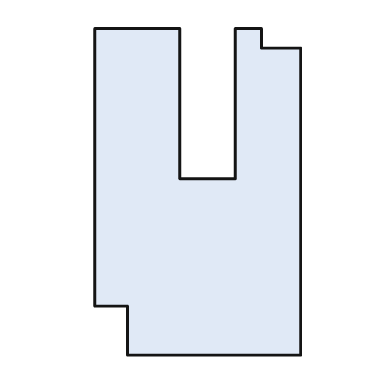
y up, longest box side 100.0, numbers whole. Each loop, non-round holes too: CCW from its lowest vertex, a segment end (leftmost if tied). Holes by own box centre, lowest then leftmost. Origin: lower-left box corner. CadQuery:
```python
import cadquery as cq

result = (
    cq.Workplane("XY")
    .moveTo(10.0, 0.0)
    .lineTo(63.0, 0.0)
    .lineTo(63.0, 94.0)
    .lineTo(51.0, 94.0)
    .lineTo(51.0, 100.0)
    .lineTo(43.0, 100.0)
    .lineTo(43.0, 54.0)
    .lineTo(26.0, 54.0)
    .lineTo(26.0, 100.0)
    .lineTo(0.0, 100.0)
    .lineTo(0.0, 15.0)
    .lineTo(10.0, 15.0)
    .close()
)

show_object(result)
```